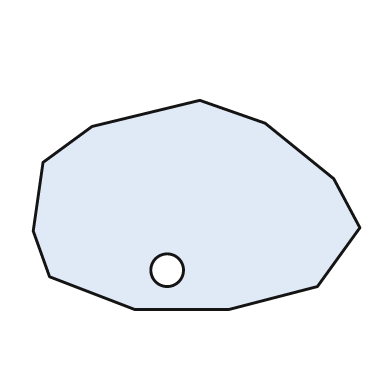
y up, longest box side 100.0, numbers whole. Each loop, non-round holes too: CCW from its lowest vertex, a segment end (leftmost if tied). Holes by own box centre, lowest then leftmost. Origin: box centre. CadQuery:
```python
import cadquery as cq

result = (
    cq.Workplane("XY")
    .moveTo(-19.0, -32.0)
    .lineTo(10.0, -32.0)
    .lineTo(37.0, -25.0)
    .lineTo(50.0, -7.0)
    .lineTo(42.0, 8.0)
    .lineTo(21.0, 25.0)
    .lineTo(1.0, 32.0)
    .lineTo(-32.0, 24.0)
    .lineTo(-47.0, 13.0)
    .lineTo(-50.0, -8.0)
    .lineTo(-45.0, -22.0)
    .close()
    .moveTo(-9.0, -20.0)
    .circle(5.0)
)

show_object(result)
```